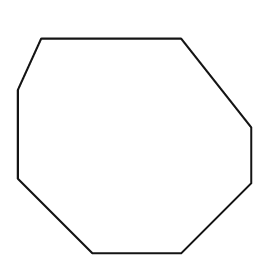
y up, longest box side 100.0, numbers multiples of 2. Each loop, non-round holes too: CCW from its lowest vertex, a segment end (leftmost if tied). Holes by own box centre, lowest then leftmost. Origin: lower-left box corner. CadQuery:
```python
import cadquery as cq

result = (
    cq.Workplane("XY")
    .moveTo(32.0, 0.0)
    .lineTo(70.0, 0.0)
    .lineTo(100.0, 30.0)
    .lineTo(100.0, 54.0)
    .lineTo(70.0, 92.0)
    .lineTo(10.0, 92.0)
    .lineTo(0.0, 70.0)
    .lineTo(0.0, 32.0)
    .close()
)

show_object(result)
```